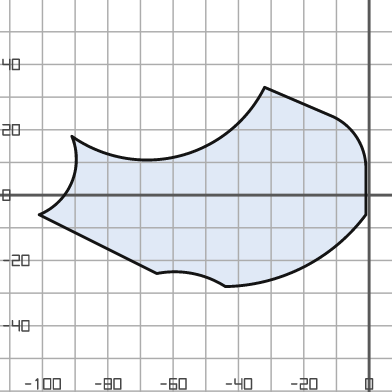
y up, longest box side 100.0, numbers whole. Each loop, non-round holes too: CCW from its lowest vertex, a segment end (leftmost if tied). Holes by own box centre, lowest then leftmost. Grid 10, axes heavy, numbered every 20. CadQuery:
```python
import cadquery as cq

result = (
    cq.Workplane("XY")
    .moveTo(-44.0, -28.0)
    .threePointArc((-20.0, -22.0), (-1.0, -6.0))
    .lineTo(-1.0, 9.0)
    .threePointArc((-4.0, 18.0), (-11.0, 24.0))
    .lineTo(-32.0, 33.0)
    .threePointArc((-58.0, 12.0), (-91.0, 18.0))
    .threePointArc((-91.0, 4.0), (-101.0, -6.0))
    .lineTo(-65.0, -24.0)
    .threePointArc((-54.0, -24.0), (-44.0, -28.0))
    .close()
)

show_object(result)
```